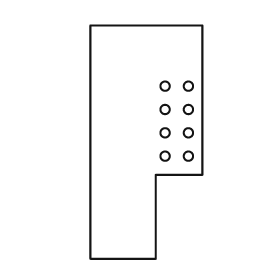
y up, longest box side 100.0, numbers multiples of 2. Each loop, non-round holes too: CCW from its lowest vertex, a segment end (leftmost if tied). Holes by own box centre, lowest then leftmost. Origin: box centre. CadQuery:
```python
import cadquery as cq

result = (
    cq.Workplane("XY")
    .moveTo(-24.0, -50.0)
    .lineTo(4.0, -50.0)
    .lineTo(4.0, -14.0)
    .lineTo(24.0, -14.0)
    .lineTo(24.0, 50.0)
    .lineTo(-24.0, 50.0)
    .close()
    .moveTo(8.0, -6.0)
    .circle(2.0)
    .moveTo(18.0, -6.0)
    .circle(2.0)
    .moveTo(8.0, 4.0)
    .circle(2.0)
    .moveTo(18.0, 4.0)
    .circle(2.0)
    .moveTo(8.0, 14.0)
    .circle(2.0)
    .moveTo(18.0, 14.0)
    .circle(2.0)
    .moveTo(8.0, 24.0)
    .circle(2.0)
    .moveTo(18.0, 24.0)
    .circle(2.0)
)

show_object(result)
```